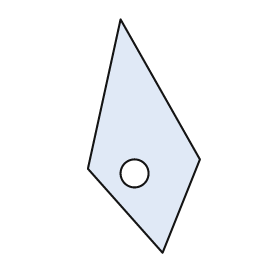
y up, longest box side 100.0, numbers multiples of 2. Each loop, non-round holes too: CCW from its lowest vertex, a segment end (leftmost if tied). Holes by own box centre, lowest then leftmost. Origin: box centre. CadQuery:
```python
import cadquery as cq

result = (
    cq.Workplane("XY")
    .moveTo(8.0, -50.0)
    .lineTo(24.0, -10.0)
    .lineTo(-10.0, 50.0)
    .lineTo(-24.0, -14.0)
    .close()
    .moveTo(-4.0, -16.0)
    .circle(6.0)
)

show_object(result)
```